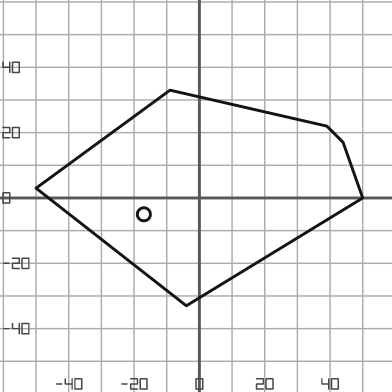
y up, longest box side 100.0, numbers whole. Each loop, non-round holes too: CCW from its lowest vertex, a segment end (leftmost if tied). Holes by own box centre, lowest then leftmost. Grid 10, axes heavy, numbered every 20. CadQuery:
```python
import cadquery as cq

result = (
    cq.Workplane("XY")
    .moveTo(-4.0, -33.0)
    .lineTo(50.0, 0.0)
    .lineTo(44.0, 17.0)
    .lineTo(39.0, 22.0)
    .lineTo(-9.0, 33.0)
    .lineTo(-50.0, 3.0)
    .close()
    .moveTo(-17.0, -5.0)
    .circle(2.0)
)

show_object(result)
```